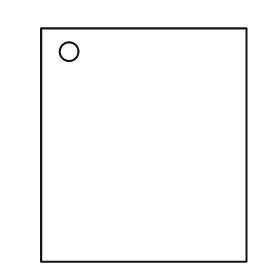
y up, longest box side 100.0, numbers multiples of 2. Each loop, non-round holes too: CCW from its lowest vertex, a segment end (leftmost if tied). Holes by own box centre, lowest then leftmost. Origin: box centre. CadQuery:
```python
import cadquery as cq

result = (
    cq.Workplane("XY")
    .moveTo(-44.0, -50.0)
    .lineTo(44.0, -50.0)
    .lineTo(44.0, 50.0)
    .lineTo(-44.0, 50.0)
    .close()
    .moveTo(-32.0, 40.0)
    .circle(4.0)
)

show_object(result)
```